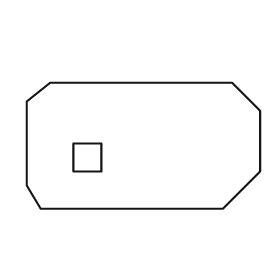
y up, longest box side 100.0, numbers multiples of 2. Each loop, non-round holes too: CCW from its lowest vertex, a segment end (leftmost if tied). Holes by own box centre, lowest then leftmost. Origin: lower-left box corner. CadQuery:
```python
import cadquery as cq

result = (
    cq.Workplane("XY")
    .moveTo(6.0, 0.0)
    .lineTo(84.0, 0.0)
    .lineTo(100.0, 16.0)
    .lineTo(100.0, 42.0)
    .lineTo(88.0, 54.0)
    .lineTo(10.0, 54.0)
    .lineTo(0.0, 46.0)
    .lineTo(0.0, 10.0)
    .close()
    .moveTo(20.0, 16.0)
    .lineTo(32.0, 16.0)
    .lineTo(32.0, 28.0)
    .lineTo(20.0, 28.0)
    .close()
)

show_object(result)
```